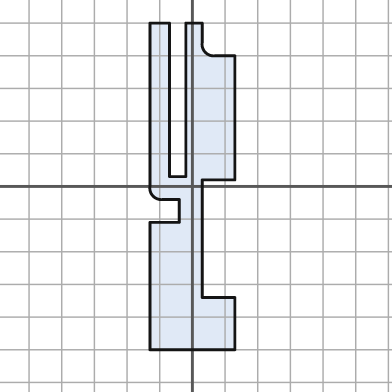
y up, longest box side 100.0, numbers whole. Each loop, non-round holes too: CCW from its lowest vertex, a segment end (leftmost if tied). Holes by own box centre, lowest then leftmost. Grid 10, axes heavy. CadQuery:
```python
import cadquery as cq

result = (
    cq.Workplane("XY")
    .moveTo(-13.0, -50.0)
    .lineTo(13.0, -50.0)
    .lineTo(13.0, -34.0)
    .lineTo(3.0, -34.0)
    .lineTo(3.0, 2.0)
    .lineTo(13.0, 2.0)
    .lineTo(13.0, 40.0)
    .lineTo(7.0, 40.0)
    .threePointArc((4.0, 41.0), (3.0, 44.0))
    .lineTo(3.0, 50.0)
    .lineTo(-2.0, 50.0)
    .lineTo(-2.0, 3.0)
    .lineTo(-7.0, 3.0)
    .lineTo(-7.0, 50.0)
    .lineTo(-13.0, 50.0)
    .lineTo(-13.0, 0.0)
    .threePointArc((-12.0, -3.0), (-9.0, -4.0))
    .lineTo(-4.0, -4.0)
    .lineTo(-4.0, -11.0)
    .lineTo(-13.0, -11.0)
    .close()
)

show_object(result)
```